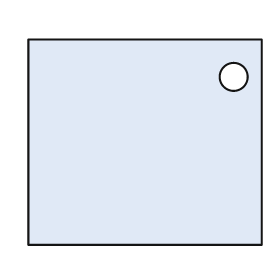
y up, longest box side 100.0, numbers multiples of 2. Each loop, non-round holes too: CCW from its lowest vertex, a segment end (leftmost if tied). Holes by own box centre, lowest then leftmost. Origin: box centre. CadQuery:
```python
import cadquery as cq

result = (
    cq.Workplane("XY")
    .moveTo(-50.0, -44.0)
    .lineTo(50.0, -44.0)
    .lineTo(50.0, 44.0)
    .lineTo(-50.0, 44.0)
    .close()
    .moveTo(38.0, 28.0)
    .circle(6.0)
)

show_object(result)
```